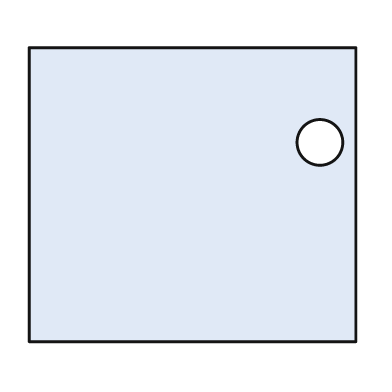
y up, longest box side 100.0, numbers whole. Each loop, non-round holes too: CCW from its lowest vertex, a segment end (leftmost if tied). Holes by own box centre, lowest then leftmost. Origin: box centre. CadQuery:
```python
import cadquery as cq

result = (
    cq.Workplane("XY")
    .moveTo(-50.0, -45.0)
    .lineTo(50.0, -45.0)
    .lineTo(50.0, 45.0)
    .lineTo(-50.0, 45.0)
    .close()
    .moveTo(39.0, 16.0)
    .circle(7.0)
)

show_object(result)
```